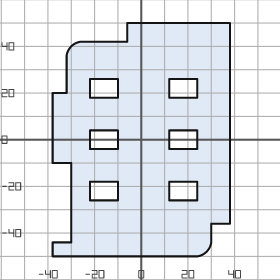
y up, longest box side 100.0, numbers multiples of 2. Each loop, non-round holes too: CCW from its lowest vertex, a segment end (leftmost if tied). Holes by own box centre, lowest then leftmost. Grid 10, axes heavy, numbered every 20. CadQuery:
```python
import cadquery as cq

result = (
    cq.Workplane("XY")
    .moveTo(-38.0, -50.0)
    .lineTo(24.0, -50.0)
    .threePointArc((28.0, -48.0), (30.0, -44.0))
    .lineTo(30.0, -36.0)
    .lineTo(38.0, -36.0)
    .lineTo(38.0, 50.0)
    .lineTo(-6.0, 50.0)
    .lineTo(-6.0, 42.0)
    .lineTo(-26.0, 42.0)
    .threePointArc((-30.0, 40.0), (-32.0, 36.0))
    .lineTo(-32.0, 20.0)
    .lineTo(-38.0, 20.0)
    .lineTo(-38.0, -10.0)
    .lineTo(-30.0, -10.0)
    .lineTo(-30.0, -44.0)
    .lineTo(-38.0, -44.0)
    .close()
    .moveTo(-22.0, -26.0)
    .lineTo(-10.0, -26.0)
    .lineTo(-10.0, -18.0)
    .lineTo(-22.0, -18.0)
    .close()
    .moveTo(12.0, -26.0)
    .lineTo(24.0, -26.0)
    .lineTo(24.0, -18.0)
    .lineTo(12.0, -18.0)
    .close()
    .moveTo(-22.0, -4.0)
    .lineTo(-10.0, -4.0)
    .lineTo(-10.0, 4.0)
    .lineTo(-22.0, 4.0)
    .close()
    .moveTo(12.0, -4.0)
    .lineTo(24.0, -4.0)
    .lineTo(24.0, 4.0)
    .lineTo(12.0, 4.0)
    .close()
    .moveTo(-22.0, 18.0)
    .lineTo(-10.0, 18.0)
    .lineTo(-10.0, 26.0)
    .lineTo(-22.0, 26.0)
    .close()
    .moveTo(12.0, 18.0)
    .lineTo(24.0, 18.0)
    .lineTo(24.0, 26.0)
    .lineTo(12.0, 26.0)
    .close()
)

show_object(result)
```